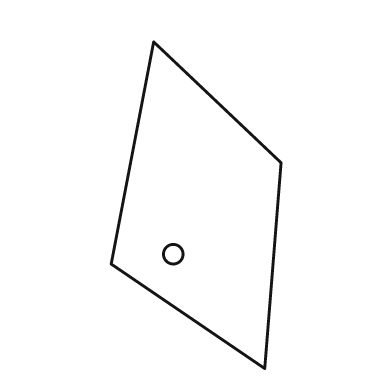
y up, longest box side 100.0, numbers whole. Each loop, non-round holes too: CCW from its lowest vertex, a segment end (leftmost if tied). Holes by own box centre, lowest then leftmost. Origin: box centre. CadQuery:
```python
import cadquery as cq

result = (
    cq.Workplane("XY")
    .moveTo(21.0, -50.0)
    .lineTo(26.0, 13.0)
    .lineTo(-13.0, 50.0)
    .lineTo(-26.0, -18.0)
    .close()
    .moveTo(-7.0, -15.0)
    .circle(3.0)
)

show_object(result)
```